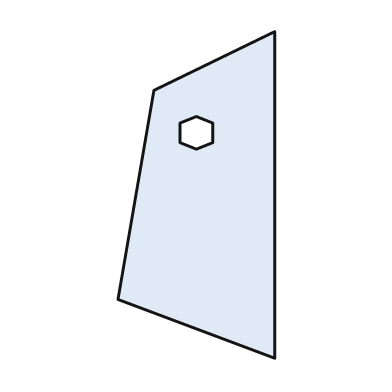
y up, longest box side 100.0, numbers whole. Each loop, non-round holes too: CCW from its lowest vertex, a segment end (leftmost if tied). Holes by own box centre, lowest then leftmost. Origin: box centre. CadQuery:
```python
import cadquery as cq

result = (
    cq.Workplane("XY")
    .moveTo(24.0, -50.0)
    .lineTo(24.0, 50.0)
    .lineTo(-13.0, 32.0)
    .lineTo(-24.0, -32.0)
    .close()
    .moveTo(0.0, 14.0)
    .lineTo(5.0, 16.0)
    .lineTo(5.0, 22.0)
    .lineTo(0.0, 24.0)
    .lineTo(-5.0, 22.0)
    .lineTo(-5.0, 16.0)
    .close()
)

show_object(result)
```